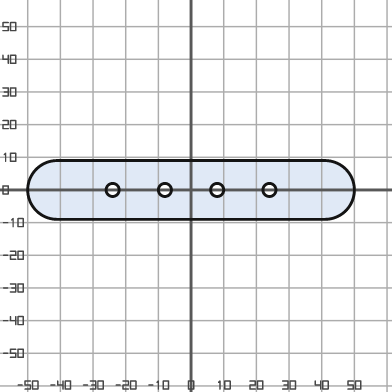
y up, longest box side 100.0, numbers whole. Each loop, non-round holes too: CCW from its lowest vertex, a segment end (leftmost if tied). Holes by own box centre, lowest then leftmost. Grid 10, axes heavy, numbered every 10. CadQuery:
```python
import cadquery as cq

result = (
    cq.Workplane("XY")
    .moveTo(-41.0, -9.0)
    .lineTo(41.0, -9.0)
    .threePointArc((50.0, 0.0), (41.0, 9.0))
    .lineTo(-41.0, 9.0)
    .threePointArc((-50.0, 0.0), (-41.0, -9.0))
    .close()
    .moveTo(-24.0, 0.0)
    .circle(2.0)
    .moveTo(-8.0, 0.0)
    .circle(2.0)
    .moveTo(8.0, 0.0)
    .circle(2.0)
    .moveTo(24.0, 0.0)
    .circle(2.0)
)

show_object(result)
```